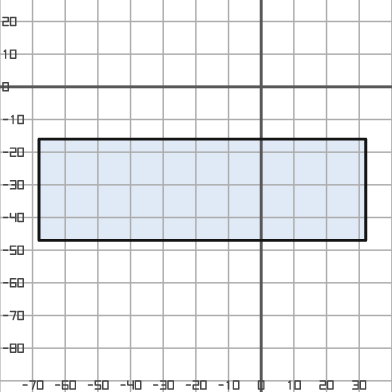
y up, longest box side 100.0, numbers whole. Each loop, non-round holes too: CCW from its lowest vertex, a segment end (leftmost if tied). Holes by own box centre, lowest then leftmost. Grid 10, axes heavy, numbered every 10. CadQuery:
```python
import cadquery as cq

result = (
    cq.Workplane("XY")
    .moveTo(-68.0, -47.0)
    .lineTo(32.0, -47.0)
    .lineTo(32.0, -16.0)
    .lineTo(-68.0, -16.0)
    .close()
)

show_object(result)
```